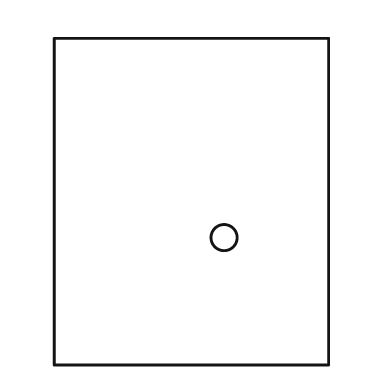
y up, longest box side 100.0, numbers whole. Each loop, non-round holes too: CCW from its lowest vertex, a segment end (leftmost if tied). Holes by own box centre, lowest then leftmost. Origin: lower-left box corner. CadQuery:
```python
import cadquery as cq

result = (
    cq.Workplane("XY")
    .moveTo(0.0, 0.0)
    .lineTo(84.0, 0.0)
    .lineTo(84.0, 100.0)
    .lineTo(0.0, 100.0)
    .close()
    .moveTo(52.0, 39.0)
    .circle(4.0)
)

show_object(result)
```